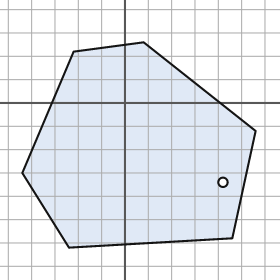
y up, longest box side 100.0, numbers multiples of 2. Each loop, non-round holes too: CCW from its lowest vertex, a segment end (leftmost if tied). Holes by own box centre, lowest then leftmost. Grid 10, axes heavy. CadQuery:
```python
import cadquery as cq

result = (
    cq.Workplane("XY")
    .moveTo(-24.0, -62.0)
    .lineTo(46.0, -58.0)
    .lineTo(56.0, -12.0)
    .lineTo(8.0, 26.0)
    .lineTo(-22.0, 22.0)
    .lineTo(-44.0, -30.0)
    .close()
    .moveTo(42.0, -34.0)
    .circle(2.0)
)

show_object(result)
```